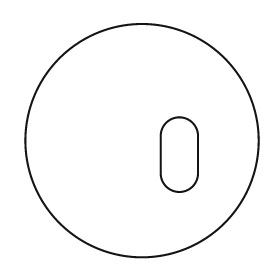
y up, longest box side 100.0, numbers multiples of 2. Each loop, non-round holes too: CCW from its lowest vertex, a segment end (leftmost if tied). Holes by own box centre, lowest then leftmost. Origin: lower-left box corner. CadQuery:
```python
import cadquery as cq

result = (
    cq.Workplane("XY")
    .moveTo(50.0, 50.0)
    .circle(50.0)
    .moveTo(58.0, 36.0)
    .threePointArc((66.0, 28.0), (74.0, 36.0))
    .lineTo(74.0, 52.0)
    .threePointArc((66.0, 60.0), (58.0, 52.0))
    .close()
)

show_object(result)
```